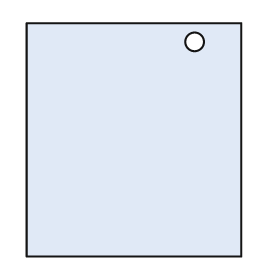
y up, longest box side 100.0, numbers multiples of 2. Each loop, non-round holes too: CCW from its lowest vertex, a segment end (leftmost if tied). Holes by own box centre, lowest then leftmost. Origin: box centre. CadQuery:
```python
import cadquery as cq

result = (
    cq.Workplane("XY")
    .moveTo(-46.0, -50.0)
    .lineTo(46.0, -50.0)
    .lineTo(46.0, 50.0)
    .lineTo(-46.0, 50.0)
    .close()
    .moveTo(26.0, 42.0)
    .circle(4.0)
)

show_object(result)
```